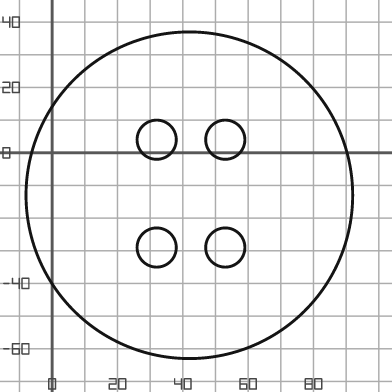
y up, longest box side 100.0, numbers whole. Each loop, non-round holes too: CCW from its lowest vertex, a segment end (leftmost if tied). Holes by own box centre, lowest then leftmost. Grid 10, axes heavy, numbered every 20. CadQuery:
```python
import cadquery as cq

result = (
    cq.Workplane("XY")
    .moveTo(42.0, -13.0)
    .circle(50.0)
    .moveTo(32.0, -29.0)
    .circle(6.0)
    .moveTo(53.0, -29.0)
    .circle(6.0)
    .moveTo(32.0, 4.0)
    .circle(6.0)
    .moveTo(53.0, 4.0)
    .circle(6.0)
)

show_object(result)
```